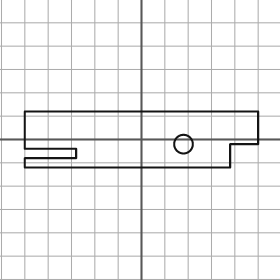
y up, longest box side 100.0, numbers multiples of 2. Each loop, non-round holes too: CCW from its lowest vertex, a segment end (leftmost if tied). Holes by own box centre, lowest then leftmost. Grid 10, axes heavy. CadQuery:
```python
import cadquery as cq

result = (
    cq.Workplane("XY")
    .moveTo(-50.0, -12.0)
    .lineTo(38.0, -12.0)
    .lineTo(38.0, -2.0)
    .lineTo(50.0, -2.0)
    .lineTo(50.0, 12.0)
    .lineTo(-50.0, 12.0)
    .lineTo(-50.0, -4.0)
    .lineTo(-28.0, -4.0)
    .lineTo(-28.0, -8.0)
    .lineTo(-50.0, -8.0)
    .close()
    .moveTo(18.0, -2.0)
    .circle(4.0)
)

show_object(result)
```